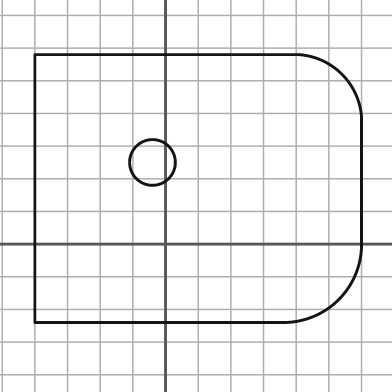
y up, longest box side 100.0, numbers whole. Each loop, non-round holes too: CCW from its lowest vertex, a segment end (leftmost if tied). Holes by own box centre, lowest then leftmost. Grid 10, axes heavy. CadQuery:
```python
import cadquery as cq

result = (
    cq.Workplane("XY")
    .moveTo(-40.0, -24.0)
    .lineTo(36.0, -24.0)
    .threePointArc((53.0, -17.0), (60.0, 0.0))
    .lineTo(60.0, 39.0)
    .threePointArc((54.0, 52.0), (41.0, 58.0))
    .lineTo(-40.0, 58.0)
    .close()
    .moveTo(-4.0, 25.0)
    .circle(7.0)
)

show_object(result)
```